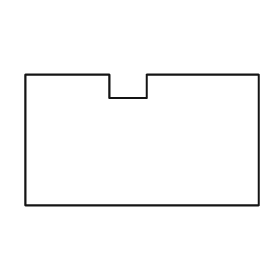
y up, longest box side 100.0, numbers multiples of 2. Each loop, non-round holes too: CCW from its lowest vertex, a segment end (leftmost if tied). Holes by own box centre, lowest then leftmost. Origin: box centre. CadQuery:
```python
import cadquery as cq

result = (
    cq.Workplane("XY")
    .moveTo(-50.0, -28.0)
    .lineTo(50.0, -28.0)
    .lineTo(50.0, 28.0)
    .lineTo(2.0, 28.0)
    .lineTo(2.0, 18.0)
    .lineTo(-14.0, 18.0)
    .lineTo(-14.0, 28.0)
    .lineTo(-50.0, 28.0)
    .close()
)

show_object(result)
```